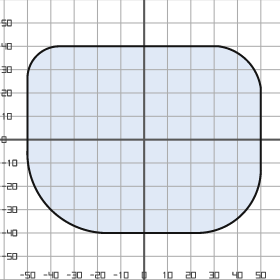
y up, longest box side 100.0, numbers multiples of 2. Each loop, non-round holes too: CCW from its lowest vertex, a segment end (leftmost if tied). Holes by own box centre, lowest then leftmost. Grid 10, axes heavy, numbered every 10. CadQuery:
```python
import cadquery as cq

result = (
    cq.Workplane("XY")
    .moveTo(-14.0, -40.0)
    .lineTo(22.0, -40.0)
    .threePointArc((42.0, -32.0), (50.0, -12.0))
    .lineTo(50.0, 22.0)
    .threePointArc((44.0, 34.0), (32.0, 40.0))
    .lineTo(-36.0, 40.0)
    .threePointArc((-46.0, 36.0), (-50.0, 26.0))
    .lineTo(-50.0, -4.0)
    .threePointArc((-40.0, -30.0), (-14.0, -40.0))
    .close()
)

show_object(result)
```